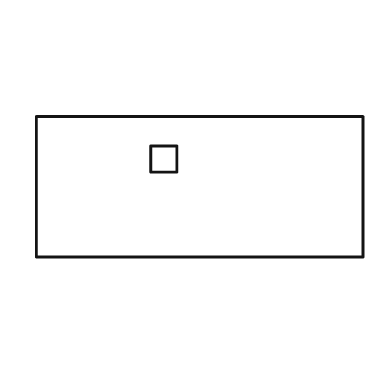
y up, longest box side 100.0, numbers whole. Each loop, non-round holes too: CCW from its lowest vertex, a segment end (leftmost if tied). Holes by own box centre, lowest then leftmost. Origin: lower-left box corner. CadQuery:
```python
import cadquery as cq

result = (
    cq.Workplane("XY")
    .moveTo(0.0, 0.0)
    .lineTo(100.0, 0.0)
    .lineTo(100.0, 43.0)
    .lineTo(0.0, 43.0)
    .close()
    .moveTo(35.0, 26.0)
    .lineTo(43.0, 26.0)
    .lineTo(43.0, 34.0)
    .lineTo(35.0, 34.0)
    .close()
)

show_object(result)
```